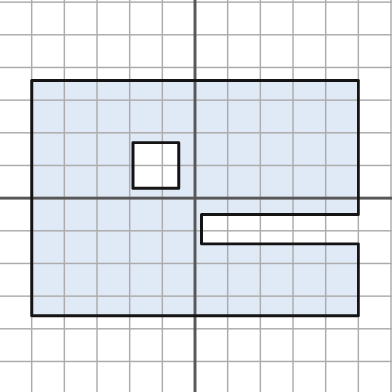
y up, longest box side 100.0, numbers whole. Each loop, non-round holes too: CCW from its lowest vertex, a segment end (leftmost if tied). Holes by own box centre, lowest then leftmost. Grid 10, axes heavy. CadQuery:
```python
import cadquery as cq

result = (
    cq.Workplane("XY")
    .moveTo(-50.0, -36.0)
    .lineTo(50.0, -36.0)
    .lineTo(50.0, -14.0)
    .lineTo(2.0, -14.0)
    .lineTo(2.0, -5.0)
    .lineTo(50.0, -5.0)
    .lineTo(50.0, 36.0)
    .lineTo(-50.0, 36.0)
    .close()
    .moveTo(-19.0, 3.0)
    .lineTo(-5.0, 3.0)
    .lineTo(-5.0, 17.0)
    .lineTo(-19.0, 17.0)
    .close()
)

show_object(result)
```